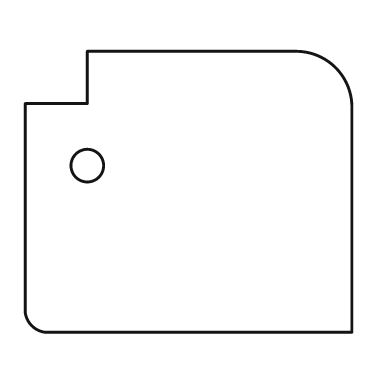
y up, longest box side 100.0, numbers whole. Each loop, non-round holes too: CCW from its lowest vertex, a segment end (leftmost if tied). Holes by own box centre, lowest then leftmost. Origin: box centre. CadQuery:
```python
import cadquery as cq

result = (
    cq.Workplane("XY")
    .moveTo(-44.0, -43.0)
    .lineTo(50.0, -43.0)
    .lineTo(50.0, 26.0)
    .threePointArc((45.0, 38.0), (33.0, 43.0))
    .lineTo(-31.0, 43.0)
    .lineTo(-31.0, 27.0)
    .lineTo(-50.0, 27.0)
    .lineTo(-50.0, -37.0)
    .threePointArc((-48.0, -41.0), (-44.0, -43.0))
    .close()
    .moveTo(-31.0, 8.0)
    .circle(5.0)
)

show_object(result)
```